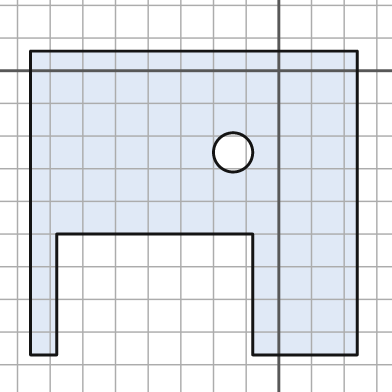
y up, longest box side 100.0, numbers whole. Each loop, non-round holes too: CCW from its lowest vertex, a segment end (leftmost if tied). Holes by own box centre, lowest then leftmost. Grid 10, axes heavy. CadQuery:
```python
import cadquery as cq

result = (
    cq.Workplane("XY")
    .moveTo(-76.0, -87.0)
    .lineTo(-68.0, -87.0)
    .lineTo(-68.0, -50.0)
    .lineTo(-8.0, -50.0)
    .lineTo(-8.0, -87.0)
    .lineTo(24.0, -87.0)
    .lineTo(24.0, 6.0)
    .lineTo(-76.0, 6.0)
    .close()
    .moveTo(-14.0, -25.0)
    .circle(6.0)
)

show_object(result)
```